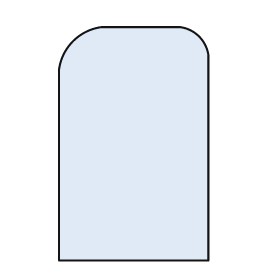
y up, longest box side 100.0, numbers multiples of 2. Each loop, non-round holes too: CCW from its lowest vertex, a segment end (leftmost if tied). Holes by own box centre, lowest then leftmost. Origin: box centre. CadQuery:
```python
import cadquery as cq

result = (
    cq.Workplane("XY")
    .moveTo(-32.0, -50.0)
    .lineTo(32.0, -50.0)
    .lineTo(32.0, 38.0)
    .threePointArc((28.0, 46.0), (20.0, 50.0))
    .lineTo(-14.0, 50.0)
    .threePointArc((-26.0, 44.0), (-32.0, 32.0))
    .close()
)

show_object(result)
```